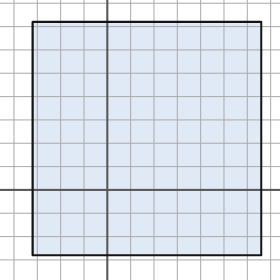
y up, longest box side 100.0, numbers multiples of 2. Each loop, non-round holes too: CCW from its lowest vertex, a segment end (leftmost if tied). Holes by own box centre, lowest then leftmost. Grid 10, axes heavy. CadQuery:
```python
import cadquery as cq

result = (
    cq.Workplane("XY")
    .moveTo(-32.0, -28.0)
    .lineTo(66.0, -28.0)
    .lineTo(66.0, 72.0)
    .lineTo(-32.0, 72.0)
    .close()
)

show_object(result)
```